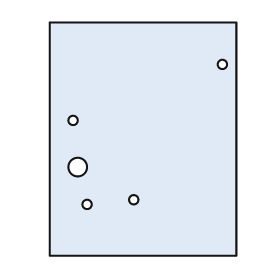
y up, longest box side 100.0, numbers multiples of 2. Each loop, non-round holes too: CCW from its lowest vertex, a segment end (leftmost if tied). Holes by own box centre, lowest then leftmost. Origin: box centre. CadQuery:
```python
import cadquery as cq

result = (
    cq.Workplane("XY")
    .moveTo(-40.0, -50.0)
    .lineTo(40.0, -50.0)
    .lineTo(40.0, 50.0)
    .lineTo(-40.0, 50.0)
    .close()
    .moveTo(-24.0, -28.0)
    .circle(2.0)
    .moveTo(-4.0, -26.0)
    .circle(2.0)
    .moveTo(-28.0, -12.0)
    .circle(4.0)
    .moveTo(-30.0, 8.0)
    .circle(2.0)
    .moveTo(34.0, 32.0)
    .circle(2.0)
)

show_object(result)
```